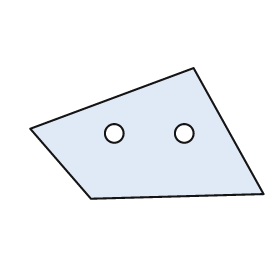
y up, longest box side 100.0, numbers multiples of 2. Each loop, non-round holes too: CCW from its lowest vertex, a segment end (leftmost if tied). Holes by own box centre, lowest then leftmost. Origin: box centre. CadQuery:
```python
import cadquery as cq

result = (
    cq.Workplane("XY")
    .moveTo(-24.0, -28.0)
    .lineTo(50.0, -26.0)
    .lineTo(20.0, 28.0)
    .lineTo(-50.0, 2.0)
    .close()
    .moveTo(-14.0, 0.0)
    .circle(4.0)
    .moveTo(16.0, 0.0)
    .circle(4.0)
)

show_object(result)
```